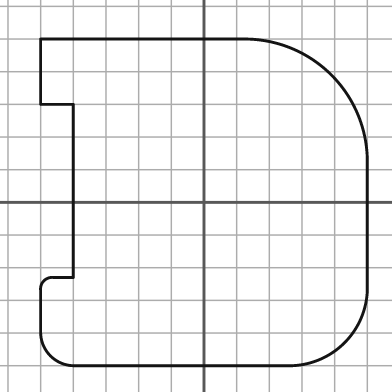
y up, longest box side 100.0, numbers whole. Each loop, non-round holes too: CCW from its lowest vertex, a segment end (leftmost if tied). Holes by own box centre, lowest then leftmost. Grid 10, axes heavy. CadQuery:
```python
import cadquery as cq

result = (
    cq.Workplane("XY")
    .moveTo(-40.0, -50.0)
    .lineTo(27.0, -50.0)
    .threePointArc((43.0, -43.0), (50.0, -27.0))
    .lineTo(50.0, 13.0)
    .threePointArc((39.0, 39.0), (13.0, 50.0))
    .lineTo(-50.0, 50.0)
    .lineTo(-50.0, 30.0)
    .lineTo(-40.0, 30.0)
    .lineTo(-40.0, -23.0)
    .lineTo(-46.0, -23.0)
    .threePointArc((-49.0, -24.0), (-50.0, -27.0))
    .lineTo(-50.0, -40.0)
    .threePointArc((-47.0, -47.0), (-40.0, -50.0))
    .close()
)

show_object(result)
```